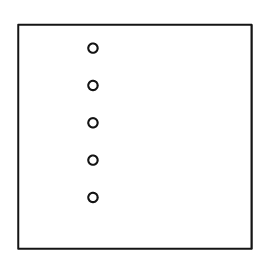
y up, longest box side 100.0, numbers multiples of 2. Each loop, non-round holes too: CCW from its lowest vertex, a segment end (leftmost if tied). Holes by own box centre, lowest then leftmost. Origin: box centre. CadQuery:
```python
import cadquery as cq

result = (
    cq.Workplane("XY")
    .moveTo(-50.0, -48.0)
    .lineTo(50.0, -48.0)
    .lineTo(50.0, 48.0)
    .lineTo(-50.0, 48.0)
    .close()
    .moveTo(-18.0, -26.0)
    .circle(2.0)
    .moveTo(-18.0, -10.0)
    .circle(2.0)
    .moveTo(-18.0, 6.0)
    .circle(2.0)
    .moveTo(-18.0, 22.0)
    .circle(2.0)
    .moveTo(-18.0, 38.0)
    .circle(2.0)
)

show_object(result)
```